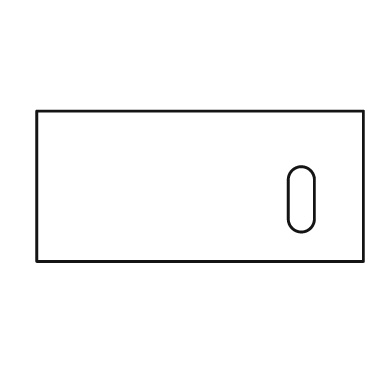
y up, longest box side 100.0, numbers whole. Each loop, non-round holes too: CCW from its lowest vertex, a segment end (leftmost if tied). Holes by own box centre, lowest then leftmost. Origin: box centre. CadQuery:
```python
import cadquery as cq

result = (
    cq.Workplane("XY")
    .moveTo(-50.0, -23.0)
    .lineTo(50.0, -23.0)
    .lineTo(50.0, 23.0)
    .lineTo(-50.0, 23.0)
    .close()
    .moveTo(27.0, -10.0)
    .threePointArc((31.0, -14.0), (35.0, -10.0))
    .lineTo(35.0, 2.0)
    .threePointArc((31.0, 6.0), (27.0, 2.0))
    .close()
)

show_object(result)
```